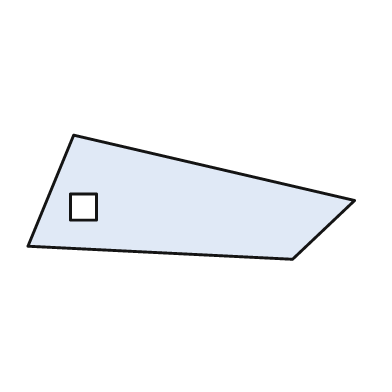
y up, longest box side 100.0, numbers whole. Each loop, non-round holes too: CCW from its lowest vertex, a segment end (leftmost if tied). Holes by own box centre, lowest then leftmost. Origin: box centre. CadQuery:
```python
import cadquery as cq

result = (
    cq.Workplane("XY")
    .moveTo(31.0, -19.0)
    .lineTo(50.0, -1.0)
    .lineTo(-36.0, 19.0)
    .lineTo(-50.0, -15.0)
    .close()
    .moveTo(-37.0, -7.0)
    .lineTo(-29.0, -7.0)
    .lineTo(-29.0, 1.0)
    .lineTo(-37.0, 1.0)
    .close()
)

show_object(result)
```